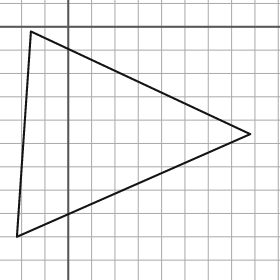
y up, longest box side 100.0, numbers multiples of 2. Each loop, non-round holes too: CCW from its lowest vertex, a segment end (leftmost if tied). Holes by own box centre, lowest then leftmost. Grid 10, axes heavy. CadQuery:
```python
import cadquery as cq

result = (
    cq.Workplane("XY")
    .moveTo(-22.0, -90.0)
    .lineTo(78.0, -46.0)
    .lineTo(-16.0, -2.0)
    .close()
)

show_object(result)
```